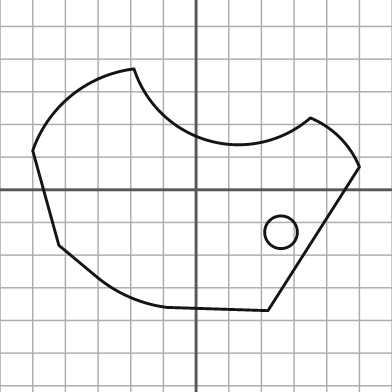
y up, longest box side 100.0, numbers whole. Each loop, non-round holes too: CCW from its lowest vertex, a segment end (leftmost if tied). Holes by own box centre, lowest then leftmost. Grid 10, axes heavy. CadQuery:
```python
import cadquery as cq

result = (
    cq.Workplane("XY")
    .moveTo(22.0, -37.0)
    .lineTo(50.0, 7.0)
    .threePointArc((44.0, 16.0), (35.0, 22.0))
    .threePointArc((4.0, 15.0), (-19.0, 37.0))
    .threePointArc((-38.0, 29.0), (-50.0, 12.0))
    .lineTo(-42.0, -17.0)
    .lineTo(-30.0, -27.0)
    .threePointArc((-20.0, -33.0), (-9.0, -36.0))
    .close()
    .moveTo(26.0, -13.0)
    .circle(5.0)
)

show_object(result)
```